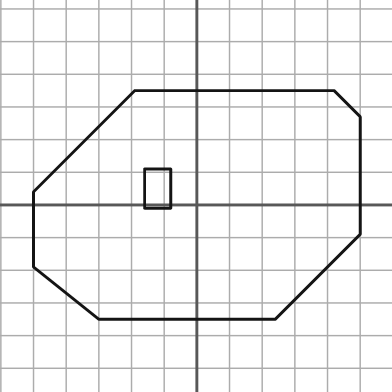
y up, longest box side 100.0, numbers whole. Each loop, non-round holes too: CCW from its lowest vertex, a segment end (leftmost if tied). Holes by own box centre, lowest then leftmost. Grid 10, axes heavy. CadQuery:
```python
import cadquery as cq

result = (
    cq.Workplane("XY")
    .moveTo(-30.0, -35.0)
    .lineTo(24.0, -35.0)
    .lineTo(50.0, -9.0)
    .lineTo(50.0, 27.0)
    .lineTo(42.0, 35.0)
    .lineTo(-19.0, 35.0)
    .lineTo(-50.0, 4.0)
    .lineTo(-50.0, -19.0)
    .close()
    .moveTo(-16.0, -1.0)
    .lineTo(-8.0, -1.0)
    .lineTo(-8.0, 11.0)
    .lineTo(-16.0, 11.0)
    .close()
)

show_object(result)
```